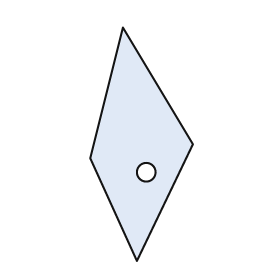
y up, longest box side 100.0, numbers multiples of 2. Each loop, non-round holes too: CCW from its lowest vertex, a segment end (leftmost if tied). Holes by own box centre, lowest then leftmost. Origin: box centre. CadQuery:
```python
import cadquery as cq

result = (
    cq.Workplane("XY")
    .moveTo(-2.0, -50.0)
    .lineTo(22.0, 0.0)
    .lineTo(-8.0, 50.0)
    .lineTo(-22.0, -6.0)
    .close()
    .moveTo(2.0, -12.0)
    .circle(4.0)
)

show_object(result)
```